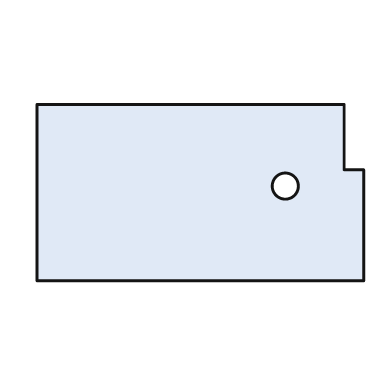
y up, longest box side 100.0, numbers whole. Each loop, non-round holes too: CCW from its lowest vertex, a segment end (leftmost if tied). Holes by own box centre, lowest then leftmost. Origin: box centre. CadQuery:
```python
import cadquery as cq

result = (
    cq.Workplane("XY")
    .moveTo(-50.0, -27.0)
    .lineTo(50.0, -27.0)
    .lineTo(50.0, 7.0)
    .lineTo(44.0, 7.0)
    .lineTo(44.0, 27.0)
    .lineTo(-50.0, 27.0)
    .close()
    .moveTo(26.0, 2.0)
    .circle(4.0)
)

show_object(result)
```